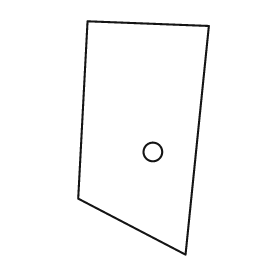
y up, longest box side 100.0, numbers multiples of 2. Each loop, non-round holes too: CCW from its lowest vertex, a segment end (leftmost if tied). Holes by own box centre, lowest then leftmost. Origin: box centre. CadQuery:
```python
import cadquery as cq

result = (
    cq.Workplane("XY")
    .moveTo(18.0, -50.0)
    .lineTo(28.0, 48.0)
    .lineTo(-24.0, 50.0)
    .lineTo(-28.0, -26.0)
    .close()
    .moveTo(4.0, -6.0)
    .circle(4.0)
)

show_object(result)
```